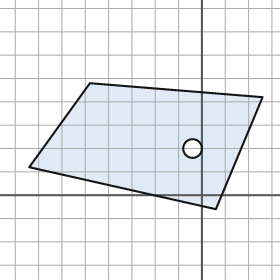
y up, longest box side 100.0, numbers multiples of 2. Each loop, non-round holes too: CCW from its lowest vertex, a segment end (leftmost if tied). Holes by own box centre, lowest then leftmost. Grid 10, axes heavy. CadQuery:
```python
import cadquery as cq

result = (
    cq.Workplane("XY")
    .moveTo(6.0, -6.0)
    .lineTo(26.0, 42.0)
    .lineTo(-48.0, 48.0)
    .lineTo(-74.0, 12.0)
    .close()
    .moveTo(-4.0, 20.0)
    .circle(4.0)
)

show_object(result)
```